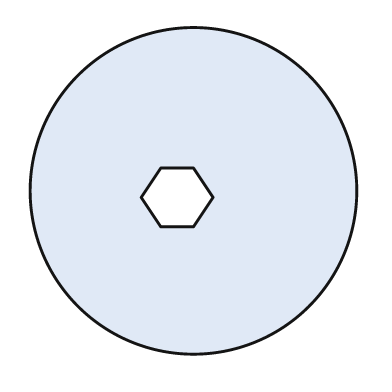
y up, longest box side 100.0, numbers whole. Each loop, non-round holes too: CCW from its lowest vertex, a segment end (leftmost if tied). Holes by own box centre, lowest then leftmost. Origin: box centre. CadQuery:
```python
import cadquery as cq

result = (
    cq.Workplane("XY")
    .moveTo(0.0, 0.0)
    .circle(50.0)
    .moveTo(-10.0, -11.0)
    .lineTo(0.0, -11.0)
    .lineTo(6.0, -2.0)
    .lineTo(0.0, 7.0)
    .lineTo(-10.0, 7.0)
    .lineTo(-16.0, -2.0)
    .close()
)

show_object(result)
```